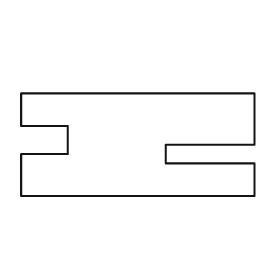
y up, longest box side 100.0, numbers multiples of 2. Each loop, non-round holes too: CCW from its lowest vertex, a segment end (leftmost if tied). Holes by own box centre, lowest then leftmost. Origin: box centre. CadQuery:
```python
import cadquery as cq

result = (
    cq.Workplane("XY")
    .moveTo(-50.0, -22.0)
    .lineTo(50.0, -22.0)
    .lineTo(50.0, -8.0)
    .lineTo(12.0, -8.0)
    .lineTo(12.0, 0.0)
    .lineTo(50.0, 0.0)
    .lineTo(50.0, 22.0)
    .lineTo(-50.0, 22.0)
    .lineTo(-50.0, 8.0)
    .lineTo(-30.0, 8.0)
    .lineTo(-30.0, -4.0)
    .lineTo(-50.0, -4.0)
    .close()
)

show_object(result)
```